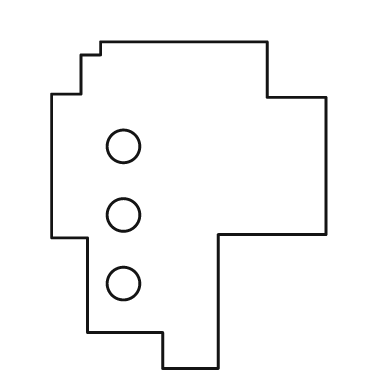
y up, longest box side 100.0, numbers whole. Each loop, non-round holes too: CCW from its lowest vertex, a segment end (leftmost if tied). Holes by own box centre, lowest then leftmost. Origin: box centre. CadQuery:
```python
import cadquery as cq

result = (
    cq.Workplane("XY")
    .moveTo(-8.0, -50.0)
    .lineTo(9.0, -50.0)
    .lineTo(9.0, -9.0)
    .lineTo(42.0, -9.0)
    .lineTo(42.0, 33.0)
    .lineTo(24.0, 33.0)
    .lineTo(24.0, 50.0)
    .lineTo(-27.0, 50.0)
    .lineTo(-27.0, 46.0)
    .lineTo(-33.0, 46.0)
    .lineTo(-33.0, 34.0)
    .lineTo(-42.0, 34.0)
    .lineTo(-42.0, -10.0)
    .lineTo(-31.0, -10.0)
    .lineTo(-31.0, -39.0)
    .lineTo(-8.0, -39.0)
    .close()
    .moveTo(-20.0, -24.0)
    .circle(5.0)
    .moveTo(-20.0, -3.0)
    .circle(5.0)
    .moveTo(-20.0, 18.0)
    .circle(5.0)
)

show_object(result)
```